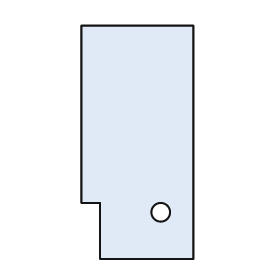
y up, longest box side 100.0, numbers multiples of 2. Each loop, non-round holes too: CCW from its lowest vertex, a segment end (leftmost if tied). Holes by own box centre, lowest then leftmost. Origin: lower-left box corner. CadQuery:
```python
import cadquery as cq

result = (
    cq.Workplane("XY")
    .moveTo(8.0, 0.0)
    .lineTo(48.0, 0.0)
    .lineTo(48.0, 100.0)
    .lineTo(0.0, 100.0)
    .lineTo(0.0, 24.0)
    .lineTo(8.0, 24.0)
    .close()
    .moveTo(34.0, 20.0)
    .circle(4.0)
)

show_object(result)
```